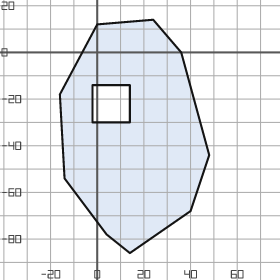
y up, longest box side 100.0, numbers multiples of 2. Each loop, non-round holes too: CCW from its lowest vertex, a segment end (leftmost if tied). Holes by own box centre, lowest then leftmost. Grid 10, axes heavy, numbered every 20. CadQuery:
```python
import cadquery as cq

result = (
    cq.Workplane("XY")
    .moveTo(14.0, -86.0)
    .lineTo(40.0, -68.0)
    .lineTo(48.0, -44.0)
    .lineTo(36.0, 0.0)
    .lineTo(24.0, 14.0)
    .lineTo(0.0, 12.0)
    .lineTo(-16.0, -18.0)
    .lineTo(-14.0, -54.0)
    .lineTo(4.0, -78.0)
    .close()
    .moveTo(-2.0, -30.0)
    .lineTo(14.0, -30.0)
    .lineTo(14.0, -14.0)
    .lineTo(-2.0, -14.0)
    .close()
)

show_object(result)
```